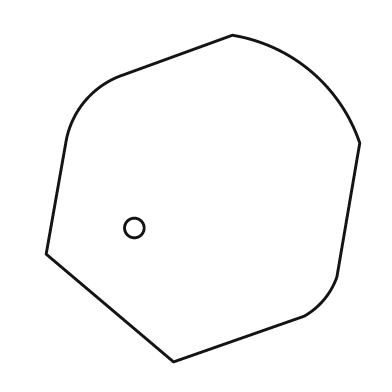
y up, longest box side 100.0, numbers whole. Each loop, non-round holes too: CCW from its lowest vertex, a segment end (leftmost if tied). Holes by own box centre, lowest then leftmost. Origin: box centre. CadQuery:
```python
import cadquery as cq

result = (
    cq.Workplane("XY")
    .moveTo(-9.0, -50.0)
    .lineTo(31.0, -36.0)
    .threePointArc((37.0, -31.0), (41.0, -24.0))
    .lineTo(48.0, 17.0)
    .threePointArc((33.0, 39.0), (9.0, 50.0))
    .lineTo(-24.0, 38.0)
    .threePointArc((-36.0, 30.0), (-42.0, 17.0))
    .lineTo(-48.0, -17.0)
    .close()
    .moveTo(-21.0, -9.0)
    .circle(3.0)
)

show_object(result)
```